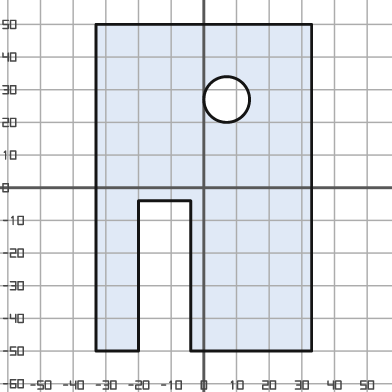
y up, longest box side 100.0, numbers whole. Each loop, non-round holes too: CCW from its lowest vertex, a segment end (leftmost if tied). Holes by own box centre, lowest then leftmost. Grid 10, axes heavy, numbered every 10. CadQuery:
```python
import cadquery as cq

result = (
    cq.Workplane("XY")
    .moveTo(-33.0, -50.0)
    .lineTo(-20.0, -50.0)
    .lineTo(-20.0, -4.0)
    .lineTo(-4.0, -4.0)
    .lineTo(-4.0, -50.0)
    .lineTo(33.0, -50.0)
    .lineTo(33.0, 50.0)
    .lineTo(-33.0, 50.0)
    .close()
    .moveTo(7.0, 27.0)
    .circle(7.0)
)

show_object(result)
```